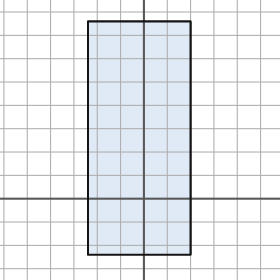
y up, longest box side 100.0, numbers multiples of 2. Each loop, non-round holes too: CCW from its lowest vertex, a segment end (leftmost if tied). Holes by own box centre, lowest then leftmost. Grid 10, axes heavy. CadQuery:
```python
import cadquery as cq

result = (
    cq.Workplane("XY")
    .moveTo(-24.0, -24.0)
    .lineTo(20.0, -24.0)
    .lineTo(20.0, 76.0)
    .lineTo(-24.0, 76.0)
    .close()
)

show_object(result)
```